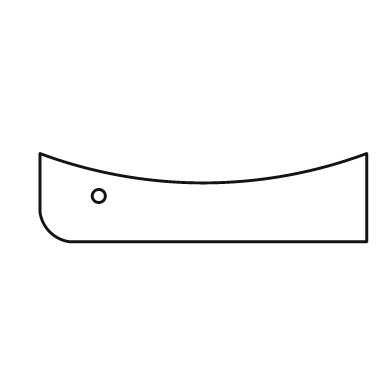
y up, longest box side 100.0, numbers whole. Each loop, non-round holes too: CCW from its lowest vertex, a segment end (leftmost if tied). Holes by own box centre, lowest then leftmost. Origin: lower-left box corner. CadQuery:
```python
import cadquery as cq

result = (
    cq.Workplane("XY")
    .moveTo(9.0, 0.0)
    .lineTo(100.0, 0.0)
    .lineTo(100.0, 27.0)
    .threePointArc((50.0, 18.0), (0.0, 27.0))
    .lineTo(0.0, 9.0)
    .threePointArc((3.0, 3.0), (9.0, 0.0))
    .close()
    .moveTo(18.0, 14.0)
    .circle(2.0)
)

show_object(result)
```